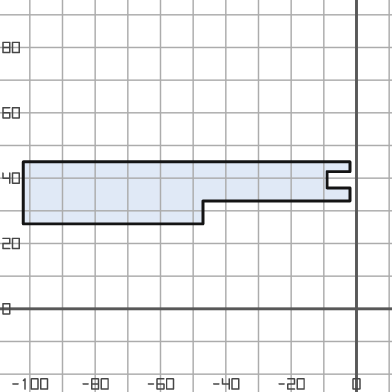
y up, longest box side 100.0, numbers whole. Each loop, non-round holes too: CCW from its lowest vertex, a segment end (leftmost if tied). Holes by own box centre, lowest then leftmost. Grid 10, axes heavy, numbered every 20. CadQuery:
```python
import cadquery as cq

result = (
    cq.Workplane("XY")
    .moveTo(-102.0, 26.0)
    .lineTo(-47.0, 26.0)
    .lineTo(-47.0, 33.0)
    .lineTo(-2.0, 33.0)
    .lineTo(-2.0, 37.0)
    .lineTo(-9.0, 37.0)
    .lineTo(-9.0, 42.0)
    .lineTo(-2.0, 42.0)
    .lineTo(-2.0, 45.0)
    .lineTo(-102.0, 45.0)
    .close()
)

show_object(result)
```